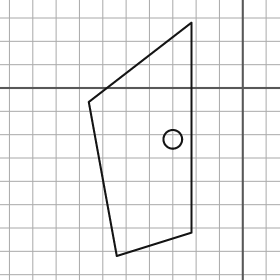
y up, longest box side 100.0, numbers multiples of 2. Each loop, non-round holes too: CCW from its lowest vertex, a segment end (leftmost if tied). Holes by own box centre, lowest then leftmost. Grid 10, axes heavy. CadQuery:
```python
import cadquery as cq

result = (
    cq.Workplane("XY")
    .moveTo(-54.0, -72.0)
    .lineTo(-22.0, -62.0)
    .lineTo(-22.0, 28.0)
    .lineTo(-66.0, -6.0)
    .close()
    .moveTo(-30.0, -22.0)
    .circle(4.0)
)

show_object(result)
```